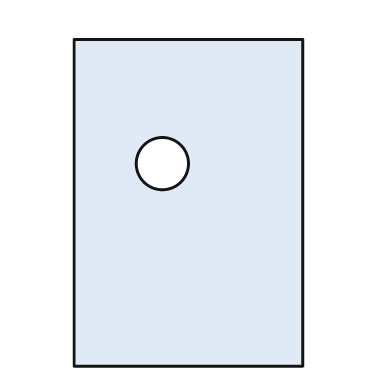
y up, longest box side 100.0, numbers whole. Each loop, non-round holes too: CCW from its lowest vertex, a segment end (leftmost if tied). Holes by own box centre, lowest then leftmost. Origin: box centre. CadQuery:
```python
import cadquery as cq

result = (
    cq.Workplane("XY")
    .moveTo(-35.0, -50.0)
    .lineTo(35.0, -50.0)
    .lineTo(35.0, 50.0)
    .lineTo(-35.0, 50.0)
    .close()
    .moveTo(-8.0, 12.0)
    .circle(8.0)
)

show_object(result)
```